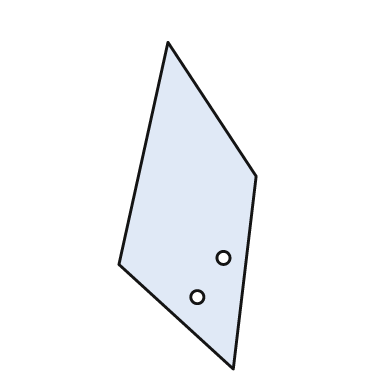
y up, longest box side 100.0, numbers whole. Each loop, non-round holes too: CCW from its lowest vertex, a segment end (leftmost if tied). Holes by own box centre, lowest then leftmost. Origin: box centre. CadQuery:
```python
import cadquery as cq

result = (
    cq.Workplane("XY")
    .moveTo(14.0, -50.0)
    .lineTo(21.0, 9.0)
    .lineTo(-6.0, 50.0)
    .lineTo(-21.0, -18.0)
    .close()
    .moveTo(3.0, -28.0)
    .circle(2.0)
    .moveTo(11.0, -16.0)
    .circle(2.0)
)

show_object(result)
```